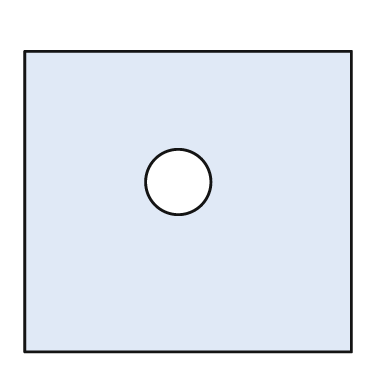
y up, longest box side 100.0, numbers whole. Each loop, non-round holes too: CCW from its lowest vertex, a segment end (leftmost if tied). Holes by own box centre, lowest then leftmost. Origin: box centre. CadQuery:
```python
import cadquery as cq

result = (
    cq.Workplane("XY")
    .moveTo(-50.0, -46.0)
    .lineTo(50.0, -46.0)
    .lineTo(50.0, 46.0)
    .lineTo(-50.0, 46.0)
    .close()
    .moveTo(-3.0, 6.0)
    .circle(10.0)
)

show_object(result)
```